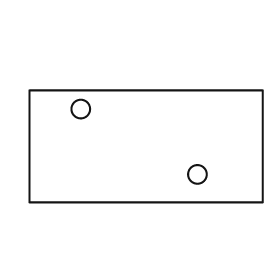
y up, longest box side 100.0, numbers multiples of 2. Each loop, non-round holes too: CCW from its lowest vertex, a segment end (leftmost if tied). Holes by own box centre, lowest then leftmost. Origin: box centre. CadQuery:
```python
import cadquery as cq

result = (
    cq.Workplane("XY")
    .moveTo(-50.0, -24.0)
    .lineTo(50.0, -24.0)
    .lineTo(50.0, 24.0)
    .lineTo(-50.0, 24.0)
    .close()
    .moveTo(22.0, -12.0)
    .circle(4.0)
    .moveTo(-28.0, 16.0)
    .circle(4.0)
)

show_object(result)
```